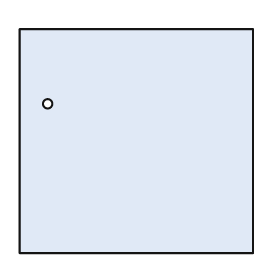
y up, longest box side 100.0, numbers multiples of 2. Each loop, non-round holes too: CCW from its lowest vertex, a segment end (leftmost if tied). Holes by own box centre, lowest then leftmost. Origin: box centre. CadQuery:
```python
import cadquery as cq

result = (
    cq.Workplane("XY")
    .moveTo(-50.0, -48.0)
    .lineTo(50.0, -48.0)
    .lineTo(50.0, 48.0)
    .lineTo(-50.0, 48.0)
    .close()
    .moveTo(-38.0, 16.0)
    .circle(2.0)
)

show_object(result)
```